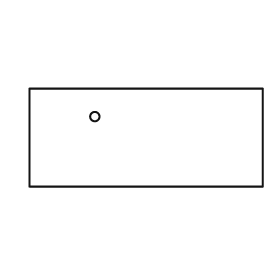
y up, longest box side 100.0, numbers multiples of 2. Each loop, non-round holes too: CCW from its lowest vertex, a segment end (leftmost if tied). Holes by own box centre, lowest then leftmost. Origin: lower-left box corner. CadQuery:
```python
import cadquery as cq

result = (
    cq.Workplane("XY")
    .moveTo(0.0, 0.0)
    .lineTo(100.0, 0.0)
    .lineTo(100.0, 42.0)
    .lineTo(0.0, 42.0)
    .close()
    .moveTo(28.0, 30.0)
    .circle(2.0)
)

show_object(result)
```